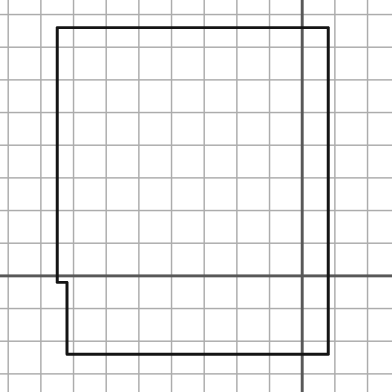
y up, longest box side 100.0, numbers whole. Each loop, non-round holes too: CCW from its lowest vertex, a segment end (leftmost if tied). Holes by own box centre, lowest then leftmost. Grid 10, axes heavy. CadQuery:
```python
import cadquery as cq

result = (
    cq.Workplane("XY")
    .moveTo(-72.0, -24.0)
    .lineTo(8.0, -24.0)
    .lineTo(8.0, 76.0)
    .lineTo(-75.0, 76.0)
    .lineTo(-75.0, -2.0)
    .lineTo(-72.0, -2.0)
    .close()
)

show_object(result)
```